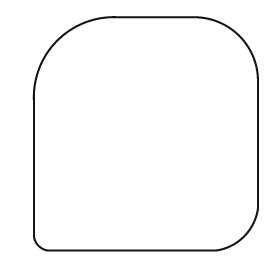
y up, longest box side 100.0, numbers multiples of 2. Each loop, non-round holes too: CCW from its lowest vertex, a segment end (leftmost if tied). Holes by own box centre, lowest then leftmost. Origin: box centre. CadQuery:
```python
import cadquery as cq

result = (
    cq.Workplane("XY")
    .moveTo(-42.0, -50.0)
    .lineTo(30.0, -50.0)
    .threePointArc((42.0, -44.0), (48.0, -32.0))
    .lineTo(48.0, 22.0)
    .threePointArc((40.0, 42.0), (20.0, 50.0))
    .lineTo(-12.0, 50.0)
    .threePointArc((-38.0, 40.0), (-48.0, 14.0))
    .lineTo(-48.0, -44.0)
    .threePointArc((-46.0, -48.0), (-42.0, -50.0))
    .close()
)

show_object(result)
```